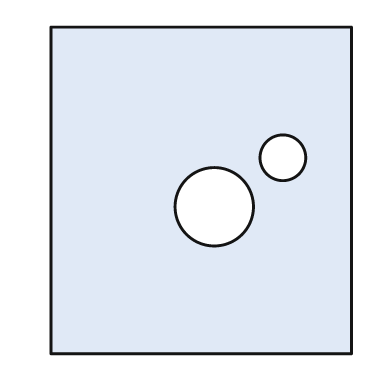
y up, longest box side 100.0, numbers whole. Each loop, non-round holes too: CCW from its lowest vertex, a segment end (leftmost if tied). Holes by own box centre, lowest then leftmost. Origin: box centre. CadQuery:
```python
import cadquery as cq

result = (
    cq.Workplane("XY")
    .moveTo(-46.0, -50.0)
    .lineTo(46.0, -50.0)
    .lineTo(46.0, 50.0)
    .lineTo(-46.0, 50.0)
    .close()
    .moveTo(4.0, -5.0)
    .circle(12.0)
    .moveTo(25.0, 10.0)
    .circle(7.0)
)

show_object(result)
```